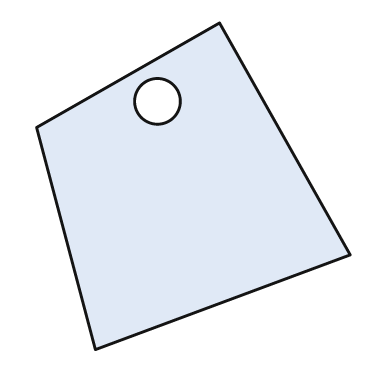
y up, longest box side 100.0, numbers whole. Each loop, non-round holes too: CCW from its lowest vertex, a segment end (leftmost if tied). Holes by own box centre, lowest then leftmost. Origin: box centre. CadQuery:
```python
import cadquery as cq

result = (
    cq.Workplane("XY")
    .moveTo(-30.0, -50.0)
    .lineTo(48.0, -21.0)
    .lineTo(8.0, 50.0)
    .lineTo(-48.0, 18.0)
    .close()
    .moveTo(-11.0, 26.0)
    .circle(7.0)
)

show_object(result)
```